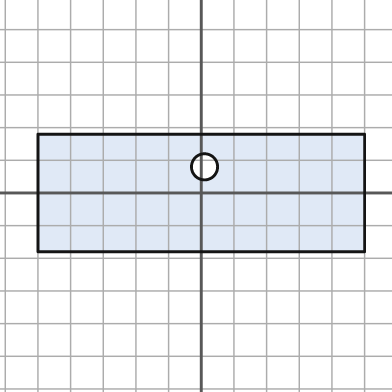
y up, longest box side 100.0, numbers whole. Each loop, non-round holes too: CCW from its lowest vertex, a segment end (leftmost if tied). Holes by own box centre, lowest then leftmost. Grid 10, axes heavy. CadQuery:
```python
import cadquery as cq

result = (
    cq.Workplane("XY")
    .moveTo(-50.0, -18.0)
    .lineTo(50.0, -18.0)
    .lineTo(50.0, 18.0)
    .lineTo(-50.0, 18.0)
    .close()
    .moveTo(1.0, 8.0)
    .circle(4.0)
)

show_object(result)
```